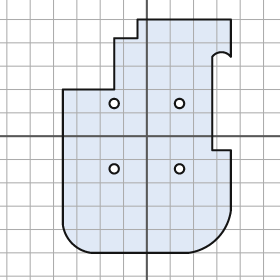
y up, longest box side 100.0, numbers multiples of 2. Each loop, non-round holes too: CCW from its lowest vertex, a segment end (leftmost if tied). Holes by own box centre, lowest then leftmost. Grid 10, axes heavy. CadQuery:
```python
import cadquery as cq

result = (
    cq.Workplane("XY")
    .moveTo(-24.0, -50.0)
    .lineTo(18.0, -50.0)
    .threePointArc((30.0, -44.0), (36.0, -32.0))
    .lineTo(36.0, -6.0)
    .lineTo(28.0, -6.0)
    .lineTo(28.0, 34.0)
    .threePointArc((32.0, 36.0), (36.0, 34.0))
    .lineTo(36.0, 50.0)
    .lineTo(-4.0, 50.0)
    .lineTo(-4.0, 42.0)
    .lineTo(-14.0, 42.0)
    .lineTo(-14.0, 20.0)
    .lineTo(-36.0, 20.0)
    .lineTo(-36.0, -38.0)
    .threePointArc((-32.0, -46.0), (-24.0, -50.0))
    .close()
    .moveTo(-14.0, -14.0)
    .circle(2.0)
    .moveTo(14.0, -14.0)
    .circle(2.0)
    .moveTo(-14.0, 14.0)
    .circle(2.0)
    .moveTo(14.0, 14.0)
    .circle(2.0)
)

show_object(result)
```